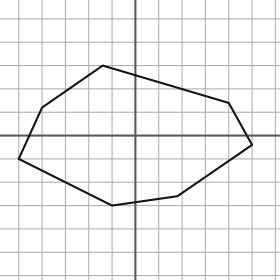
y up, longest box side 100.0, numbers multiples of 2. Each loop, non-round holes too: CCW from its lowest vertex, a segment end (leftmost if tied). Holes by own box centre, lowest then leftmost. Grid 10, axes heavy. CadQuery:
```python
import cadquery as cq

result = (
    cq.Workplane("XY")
    .moveTo(-10.0, -30.0)
    .lineTo(18.0, -26.0)
    .lineTo(50.0, -4.0)
    .lineTo(40.0, 14.0)
    .lineTo(-14.0, 30.0)
    .lineTo(-40.0, 12.0)
    .lineTo(-50.0, -10.0)
    .close()
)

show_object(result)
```